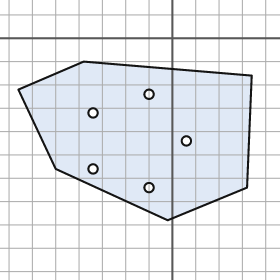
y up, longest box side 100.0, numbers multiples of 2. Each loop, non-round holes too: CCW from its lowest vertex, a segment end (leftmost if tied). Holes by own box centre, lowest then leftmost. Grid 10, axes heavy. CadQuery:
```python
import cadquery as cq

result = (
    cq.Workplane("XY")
    .moveTo(-2.0, -78.0)
    .lineTo(32.0, -64.0)
    .lineTo(34.0, -16.0)
    .lineTo(-38.0, -10.0)
    .lineTo(-66.0, -22.0)
    .lineTo(-50.0, -56.0)
    .close()
    .moveTo(-10.0, -64.0)
    .circle(2.0)
    .moveTo(-34.0, -56.0)
    .circle(2.0)
    .moveTo(6.0, -44.0)
    .circle(2.0)
    .moveTo(-34.0, -32.0)
    .circle(2.0)
    .moveTo(-10.0, -24.0)
    .circle(2.0)
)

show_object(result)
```